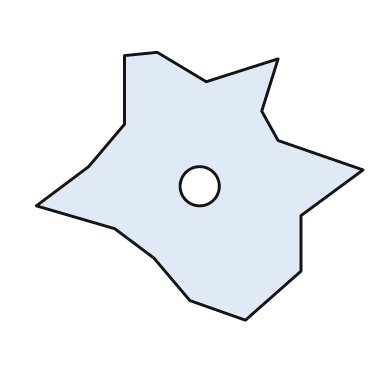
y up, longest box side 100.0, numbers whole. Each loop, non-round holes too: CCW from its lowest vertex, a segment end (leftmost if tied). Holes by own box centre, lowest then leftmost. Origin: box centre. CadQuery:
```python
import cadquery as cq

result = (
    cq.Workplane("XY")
    .moveTo(14.0, -41.0)
    .lineTo(31.0, -26.0)
    .lineTo(31.0, -9.0)
    .lineTo(50.0, 5.0)
    .lineTo(24.0, 14.0)
    .lineTo(19.0, 23.0)
    .lineTo(24.0, 39.0)
    .lineTo(2.0, 32.0)
    .lineTo(-13.0, 41.0)
    .lineTo(-23.0, 40.0)
    .lineTo(-23.0, 19.0)
    .lineTo(-34.0, 6.0)
    .lineTo(-50.0, -6.0)
    .lineTo(-26.0, -13.0)
    .lineTo(-14.0, -22.0)
    .lineTo(-3.0, -35.0)
    .close()
    .moveTo(0.0, 0.0)
    .circle(6.0)
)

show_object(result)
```